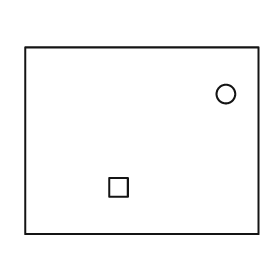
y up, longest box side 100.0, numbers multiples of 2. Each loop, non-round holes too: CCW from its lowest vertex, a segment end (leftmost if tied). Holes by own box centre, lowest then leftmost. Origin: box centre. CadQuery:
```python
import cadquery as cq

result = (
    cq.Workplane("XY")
    .moveTo(-50.0, -40.0)
    .lineTo(50.0, -40.0)
    .lineTo(50.0, 40.0)
    .lineTo(-50.0, 40.0)
    .close()
    .moveTo(-14.0, -24.0)
    .lineTo(-6.0, -24.0)
    .lineTo(-6.0, -16.0)
    .lineTo(-14.0, -16.0)
    .close()
    .moveTo(36.0, 20.0)
    .circle(4.0)
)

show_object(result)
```